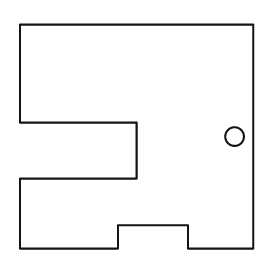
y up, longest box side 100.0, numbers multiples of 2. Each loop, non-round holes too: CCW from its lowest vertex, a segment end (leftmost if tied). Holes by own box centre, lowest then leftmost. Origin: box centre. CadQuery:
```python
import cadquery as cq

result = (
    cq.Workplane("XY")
    .moveTo(-50.0, -48.0)
    .lineTo(-8.0, -48.0)
    .lineTo(-8.0, -38.0)
    .lineTo(22.0, -38.0)
    .lineTo(22.0, -48.0)
    .lineTo(50.0, -48.0)
    .lineTo(50.0, 48.0)
    .lineTo(-50.0, 48.0)
    .lineTo(-50.0, 6.0)
    .lineTo(0.0, 6.0)
    .lineTo(0.0, -18.0)
    .lineTo(-50.0, -18.0)
    .close()
    .moveTo(42.0, 0.0)
    .circle(4.0)
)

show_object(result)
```